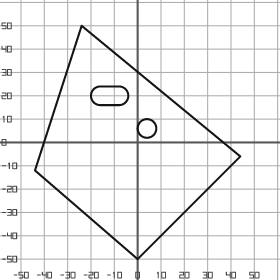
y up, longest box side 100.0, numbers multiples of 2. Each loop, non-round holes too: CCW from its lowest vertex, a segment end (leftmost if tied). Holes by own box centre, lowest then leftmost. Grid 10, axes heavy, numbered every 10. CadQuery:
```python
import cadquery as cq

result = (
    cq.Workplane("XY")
    .moveTo(0.0, -50.0)
    .lineTo(44.0, -6.0)
    .lineTo(-24.0, 50.0)
    .lineTo(-44.0, -12.0)
    .close()
    .moveTo(4.0, 6.0)
    .circle(4.0)
    .moveTo(-16.0, 16.0)
    .lineTo(-8.0, 16.0)
    .threePointArc((-4.0, 20.0), (-8.0, 24.0))
    .lineTo(-16.0, 24.0)
    .threePointArc((-20.0, 20.0), (-16.0, 16.0))
    .close()
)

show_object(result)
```